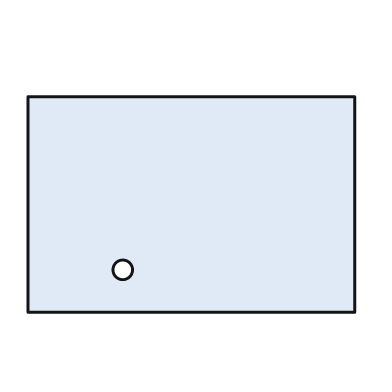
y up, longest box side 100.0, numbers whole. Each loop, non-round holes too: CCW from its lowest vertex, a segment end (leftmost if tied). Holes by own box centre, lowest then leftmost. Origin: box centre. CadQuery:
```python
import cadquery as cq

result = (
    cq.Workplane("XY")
    .moveTo(-50.0, -33.0)
    .lineTo(50.0, -33.0)
    .lineTo(50.0, 33.0)
    .lineTo(-50.0, 33.0)
    .close()
    .moveTo(-21.0, -20.0)
    .circle(3.0)
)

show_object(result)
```